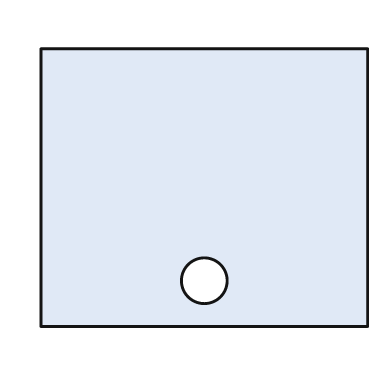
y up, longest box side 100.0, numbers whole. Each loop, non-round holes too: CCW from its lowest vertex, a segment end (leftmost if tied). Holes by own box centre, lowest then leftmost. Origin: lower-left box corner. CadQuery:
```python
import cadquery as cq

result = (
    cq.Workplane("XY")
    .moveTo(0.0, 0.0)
    .lineTo(100.0, 0.0)
    .lineTo(100.0, 85.0)
    .lineTo(0.0, 85.0)
    .close()
    .moveTo(50.0, 14.0)
    .circle(7.0)
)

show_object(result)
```